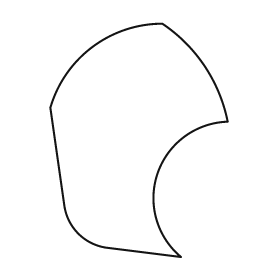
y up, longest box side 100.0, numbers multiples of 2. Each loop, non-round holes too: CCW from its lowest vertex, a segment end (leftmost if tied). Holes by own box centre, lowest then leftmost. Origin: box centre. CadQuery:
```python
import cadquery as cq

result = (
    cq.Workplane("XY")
    .moveTo(18.0, -50.0)
    .threePointArc((8.0, -14.0), (38.0, 8.0))
    .threePointArc((28.0, 32.0), (10.0, 50.0))
    .threePointArc((-20.0, 40.0), (-38.0, 14.0))
    .lineTo(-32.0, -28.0)
    .threePointArc((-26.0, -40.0), (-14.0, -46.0))
    .close()
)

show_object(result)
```